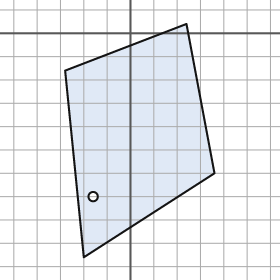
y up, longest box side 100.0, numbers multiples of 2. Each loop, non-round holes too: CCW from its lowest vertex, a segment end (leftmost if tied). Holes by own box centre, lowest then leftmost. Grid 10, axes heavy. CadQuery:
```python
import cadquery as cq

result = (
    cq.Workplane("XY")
    .moveTo(-20.0, -96.0)
    .lineTo(36.0, -60.0)
    .lineTo(24.0, 4.0)
    .lineTo(-28.0, -16.0)
    .close()
    .moveTo(-16.0, -70.0)
    .circle(2.0)
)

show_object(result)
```